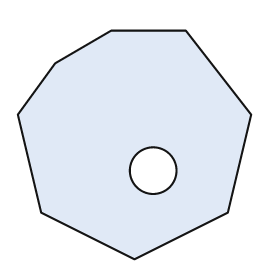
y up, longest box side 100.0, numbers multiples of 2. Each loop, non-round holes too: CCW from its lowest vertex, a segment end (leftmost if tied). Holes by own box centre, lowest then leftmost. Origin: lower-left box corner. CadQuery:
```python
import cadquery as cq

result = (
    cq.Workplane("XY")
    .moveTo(50.0, 0.0)
    .lineTo(90.0, 20.0)
    .lineTo(100.0, 62.0)
    .lineTo(72.0, 98.0)
    .lineTo(40.0, 98.0)
    .lineTo(16.0, 84.0)
    .lineTo(0.0, 62.0)
    .lineTo(10.0, 20.0)
    .close()
    .moveTo(58.0, 38.0)
    .circle(10.0)
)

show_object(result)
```